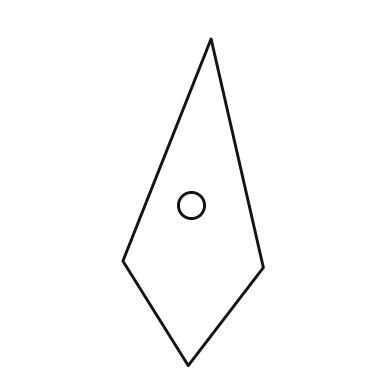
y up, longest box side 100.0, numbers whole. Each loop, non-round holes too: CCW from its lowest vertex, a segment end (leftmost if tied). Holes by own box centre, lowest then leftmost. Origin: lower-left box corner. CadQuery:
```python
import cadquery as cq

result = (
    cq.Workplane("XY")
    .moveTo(20.0, 0.0)
    .lineTo(43.0, 30.0)
    .lineTo(27.0, 100.0)
    .lineTo(0.0, 32.0)
    .close()
    .moveTo(21.0, 49.0)
    .circle(4.0)
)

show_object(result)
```